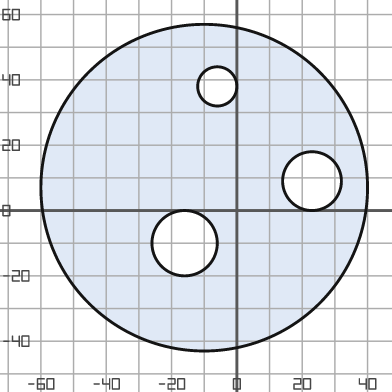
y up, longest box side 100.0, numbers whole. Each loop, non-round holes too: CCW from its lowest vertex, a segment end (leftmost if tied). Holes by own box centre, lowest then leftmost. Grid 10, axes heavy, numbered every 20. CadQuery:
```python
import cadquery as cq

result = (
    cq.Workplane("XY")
    .moveTo(-10.0, 7.0)
    .circle(50.0)
    .moveTo(-16.0, -10.0)
    .circle(10.0)
    .moveTo(23.0, 9.0)
    .circle(9.0)
    .moveTo(-6.0, 38.0)
    .circle(6.0)
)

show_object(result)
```